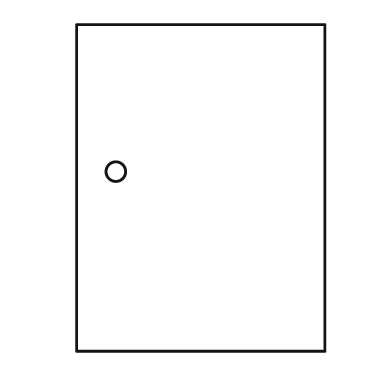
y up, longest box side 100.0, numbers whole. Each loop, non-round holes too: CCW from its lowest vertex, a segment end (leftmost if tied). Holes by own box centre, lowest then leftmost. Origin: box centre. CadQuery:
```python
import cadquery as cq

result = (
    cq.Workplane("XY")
    .moveTo(-38.0, -50.0)
    .lineTo(38.0, -50.0)
    .lineTo(38.0, 50.0)
    .lineTo(-38.0, 50.0)
    .close()
    .moveTo(-26.0, 5.0)
    .circle(3.0)
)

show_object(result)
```